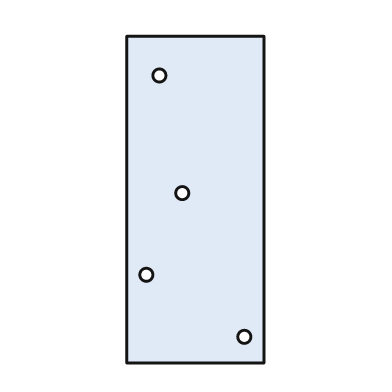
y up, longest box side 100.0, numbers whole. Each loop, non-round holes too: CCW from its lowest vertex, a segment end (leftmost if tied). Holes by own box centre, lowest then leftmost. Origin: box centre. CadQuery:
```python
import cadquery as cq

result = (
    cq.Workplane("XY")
    .moveTo(-21.0, -50.0)
    .lineTo(21.0, -50.0)
    .lineTo(21.0, 50.0)
    .lineTo(-21.0, 50.0)
    .close()
    .moveTo(15.0, -42.0)
    .circle(2.0)
    .moveTo(-15.0, -23.0)
    .circle(2.0)
    .moveTo(-4.0, 2.0)
    .circle(2.0)
    .moveTo(-11.0, 38.0)
    .circle(2.0)
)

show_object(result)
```